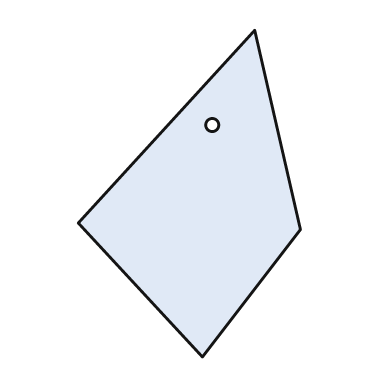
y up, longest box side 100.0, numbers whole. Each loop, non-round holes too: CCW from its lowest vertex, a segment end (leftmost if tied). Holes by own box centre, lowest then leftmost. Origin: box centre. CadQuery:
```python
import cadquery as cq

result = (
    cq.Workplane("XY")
    .moveTo(4.0, -50.0)
    .lineTo(34.0, -11.0)
    .lineTo(20.0, 50.0)
    .lineTo(-34.0, -9.0)
    .close()
    .moveTo(7.0, 21.0)
    .circle(2.0)
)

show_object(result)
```